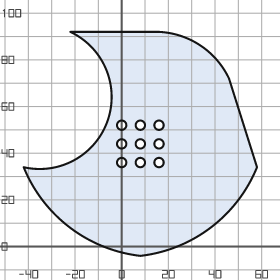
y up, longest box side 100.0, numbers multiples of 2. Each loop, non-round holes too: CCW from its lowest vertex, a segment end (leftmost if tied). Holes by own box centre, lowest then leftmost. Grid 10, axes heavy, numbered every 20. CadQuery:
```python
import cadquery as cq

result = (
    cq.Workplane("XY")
    .moveTo(8.0, -4.0)
    .threePointArc((38.0, 8.0), (58.0, 34.0))
    .lineTo(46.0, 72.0)
    .threePointArc((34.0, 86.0), (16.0, 92.0))
    .lineTo(-22.0, 92.0)
    .threePointArc((-6.0, 54.0), (-42.0, 34.0))
    .threePointArc((-22.0, 8.0), (8.0, -4.0))
    .close()
    .moveTo(0.0, 36.0)
    .circle(2.0)
    .moveTo(8.0, 36.0)
    .circle(2.0)
    .moveTo(16.0, 36.0)
    .circle(2.0)
    .moveTo(0.0, 44.0)
    .circle(2.0)
    .moveTo(8.0, 44.0)
    .circle(2.0)
    .moveTo(16.0, 44.0)
    .circle(2.0)
    .moveTo(0.0, 52.0)
    .circle(2.0)
    .moveTo(8.0, 52.0)
    .circle(2.0)
    .moveTo(16.0, 52.0)
    .circle(2.0)
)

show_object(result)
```